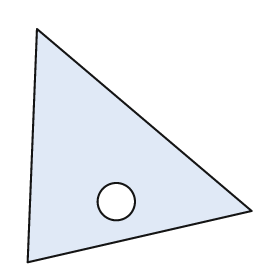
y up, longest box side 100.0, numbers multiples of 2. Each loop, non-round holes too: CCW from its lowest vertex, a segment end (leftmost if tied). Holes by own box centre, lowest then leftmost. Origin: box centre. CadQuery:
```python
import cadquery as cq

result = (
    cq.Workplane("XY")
    .moveTo(-48.0, -50.0)
    .lineTo(48.0, -28.0)
    .lineTo(-44.0, 50.0)
    .close()
    .moveTo(-10.0, -24.0)
    .circle(8.0)
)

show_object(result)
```